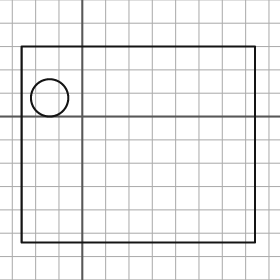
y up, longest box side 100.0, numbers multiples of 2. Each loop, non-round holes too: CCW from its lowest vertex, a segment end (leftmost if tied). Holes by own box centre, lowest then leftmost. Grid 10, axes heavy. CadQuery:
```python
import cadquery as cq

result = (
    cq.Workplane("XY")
    .moveTo(-26.0, -54.0)
    .lineTo(74.0, -54.0)
    .lineTo(74.0, 30.0)
    .lineTo(-26.0, 30.0)
    .close()
    .moveTo(-14.0, 8.0)
    .circle(8.0)
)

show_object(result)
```